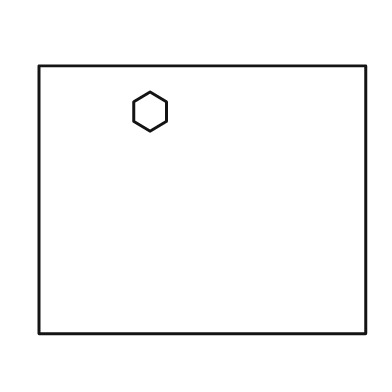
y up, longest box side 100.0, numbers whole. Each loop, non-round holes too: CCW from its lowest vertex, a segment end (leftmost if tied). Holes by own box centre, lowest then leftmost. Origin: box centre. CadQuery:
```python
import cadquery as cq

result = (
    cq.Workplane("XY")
    .moveTo(-50.0, -41.0)
    .lineTo(50.0, -41.0)
    .lineTo(50.0, 41.0)
    .lineTo(-50.0, 41.0)
    .close()
    .moveTo(-16.0, 21.0)
    .lineTo(-11.0, 24.0)
    .lineTo(-11.0, 30.0)
    .lineTo(-16.0, 33.0)
    .lineTo(-21.0, 30.0)
    .lineTo(-21.0, 24.0)
    .close()
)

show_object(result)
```